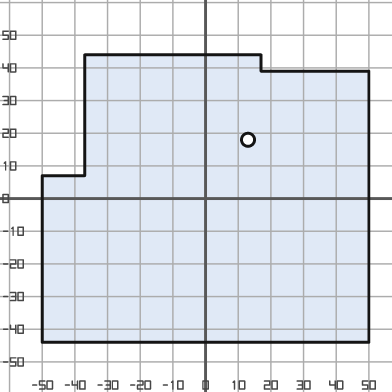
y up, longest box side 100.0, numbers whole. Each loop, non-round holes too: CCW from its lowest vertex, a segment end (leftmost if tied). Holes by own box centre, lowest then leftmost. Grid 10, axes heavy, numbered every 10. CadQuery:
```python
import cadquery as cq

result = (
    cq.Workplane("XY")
    .moveTo(-50.0, -44.0)
    .lineTo(50.0, -44.0)
    .lineTo(50.0, 39.0)
    .lineTo(17.0, 39.0)
    .lineTo(17.0, 44.0)
    .lineTo(-37.0, 44.0)
    .lineTo(-37.0, 7.0)
    .lineTo(-50.0, 7.0)
    .close()
    .moveTo(13.0, 18.0)
    .circle(2.0)
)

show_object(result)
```